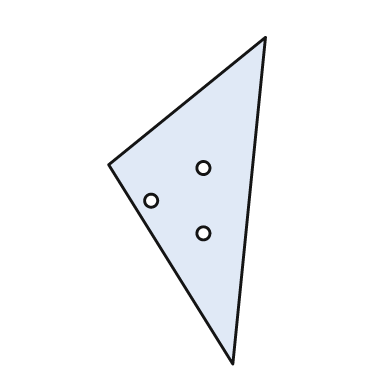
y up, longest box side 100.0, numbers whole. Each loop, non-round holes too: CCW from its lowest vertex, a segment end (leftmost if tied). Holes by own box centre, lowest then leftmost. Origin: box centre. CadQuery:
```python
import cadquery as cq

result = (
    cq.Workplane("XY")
    .moveTo(14.0, -50.0)
    .lineTo(24.0, 50.0)
    .lineTo(-24.0, 11.0)
    .close()
    .moveTo(5.0, -10.0)
    .circle(2.0)
    .moveTo(-11.0, 0.0)
    .circle(2.0)
    .moveTo(5.0, 10.0)
    .circle(2.0)
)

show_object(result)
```